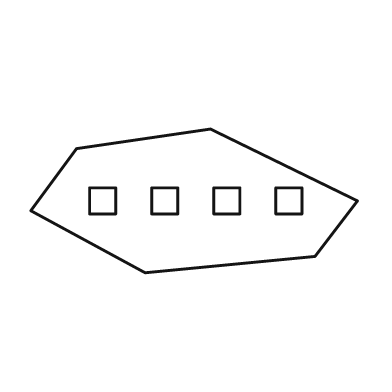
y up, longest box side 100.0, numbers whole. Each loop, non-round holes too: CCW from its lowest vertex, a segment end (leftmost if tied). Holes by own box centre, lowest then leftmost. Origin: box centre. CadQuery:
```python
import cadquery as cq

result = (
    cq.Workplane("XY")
    .moveTo(-15.0, -22.0)
    .lineTo(37.0, -17.0)
    .lineTo(50.0, 0.0)
    .lineTo(5.0, 22.0)
    .lineTo(-36.0, 16.0)
    .lineTo(-50.0, -3.0)
    .close()
    .moveTo(-32.0, -4.0)
    .lineTo(-24.0, -4.0)
    .lineTo(-24.0, 4.0)
    .lineTo(-32.0, 4.0)
    .close()
    .moveTo(-13.0, -4.0)
    .lineTo(-5.0, -4.0)
    .lineTo(-5.0, 4.0)
    .lineTo(-13.0, 4.0)
    .close()
    .moveTo(6.0, -4.0)
    .lineTo(14.0, -4.0)
    .lineTo(14.0, 4.0)
    .lineTo(6.0, 4.0)
    .close()
    .moveTo(25.0, -4.0)
    .lineTo(33.0, -4.0)
    .lineTo(33.0, 4.0)
    .lineTo(25.0, 4.0)
    .close()
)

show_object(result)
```